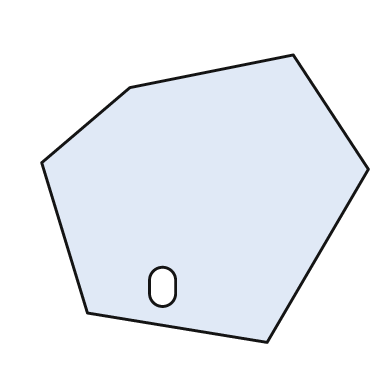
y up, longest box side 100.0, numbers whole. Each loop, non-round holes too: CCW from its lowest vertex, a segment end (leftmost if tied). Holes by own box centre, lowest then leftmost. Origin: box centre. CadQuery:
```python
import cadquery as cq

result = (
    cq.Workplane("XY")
    .moveTo(19.0, -44.0)
    .lineTo(50.0, 9.0)
    .lineTo(27.0, 44.0)
    .lineTo(-23.0, 34.0)
    .lineTo(-50.0, 11.0)
    .lineTo(-36.0, -35.0)
    .close()
    .moveTo(-17.0, -29.0)
    .threePointArc((-13.0, -33.0), (-9.0, -29.0))
    .lineTo(-9.0, -25.0)
    .threePointArc((-13.0, -21.0), (-17.0, -25.0))
    .close()
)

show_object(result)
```